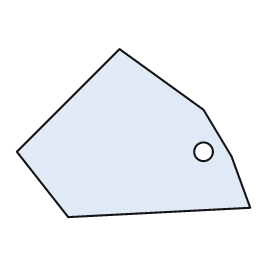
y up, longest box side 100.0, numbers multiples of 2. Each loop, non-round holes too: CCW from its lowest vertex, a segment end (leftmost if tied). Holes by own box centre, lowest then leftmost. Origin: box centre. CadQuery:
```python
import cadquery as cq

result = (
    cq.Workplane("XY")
    .moveTo(-28.0, -36.0)
    .lineTo(50.0, -32.0)
    .lineTo(42.0, -10.0)
    .lineTo(30.0, 10.0)
    .lineTo(-6.0, 36.0)
    .lineTo(-50.0, -8.0)
    .close()
    .moveTo(30.0, -8.0)
    .circle(4.0)
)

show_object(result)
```